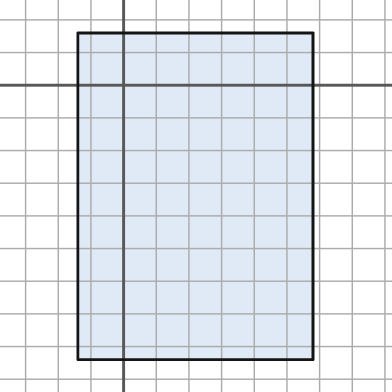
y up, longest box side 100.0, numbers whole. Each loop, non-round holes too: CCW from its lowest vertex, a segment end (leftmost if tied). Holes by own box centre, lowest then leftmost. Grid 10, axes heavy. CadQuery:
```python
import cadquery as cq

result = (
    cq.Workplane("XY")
    .moveTo(-14.0, -84.0)
    .lineTo(58.0, -84.0)
    .lineTo(58.0, 16.0)
    .lineTo(-14.0, 16.0)
    .close()
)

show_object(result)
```